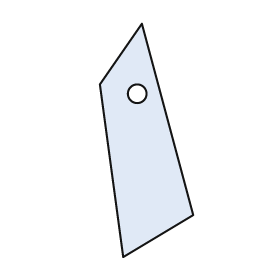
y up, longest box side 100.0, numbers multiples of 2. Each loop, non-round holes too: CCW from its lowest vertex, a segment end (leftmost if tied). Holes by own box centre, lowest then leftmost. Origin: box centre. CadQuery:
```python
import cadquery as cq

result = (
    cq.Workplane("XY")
    .moveTo(-10.0, -50.0)
    .lineTo(20.0, -32.0)
    .lineTo(-2.0, 50.0)
    .lineTo(-20.0, 24.0)
    .close()
    .moveTo(-4.0, 20.0)
    .circle(4.0)
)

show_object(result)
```